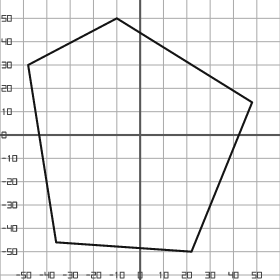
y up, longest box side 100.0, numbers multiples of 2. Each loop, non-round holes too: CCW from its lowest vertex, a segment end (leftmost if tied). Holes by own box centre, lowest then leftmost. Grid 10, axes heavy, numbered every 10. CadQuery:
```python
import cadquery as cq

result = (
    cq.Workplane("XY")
    .moveTo(22.0, -50.0)
    .lineTo(48.0, 14.0)
    .lineTo(-10.0, 50.0)
    .lineTo(-48.0, 30.0)
    .lineTo(-36.0, -46.0)
    .close()
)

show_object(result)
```